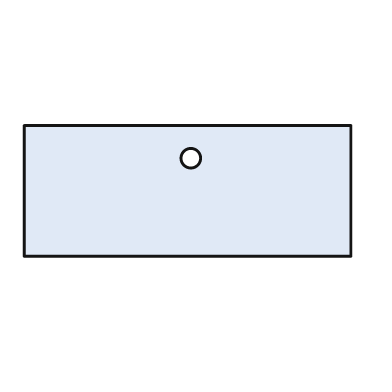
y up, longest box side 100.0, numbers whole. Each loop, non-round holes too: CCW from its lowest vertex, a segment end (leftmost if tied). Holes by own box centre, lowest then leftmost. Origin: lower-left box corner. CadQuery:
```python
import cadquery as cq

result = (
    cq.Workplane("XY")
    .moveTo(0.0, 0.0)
    .lineTo(100.0, 0.0)
    .lineTo(100.0, 40.0)
    .lineTo(0.0, 40.0)
    .close()
    .moveTo(51.0, 30.0)
    .circle(3.0)
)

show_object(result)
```